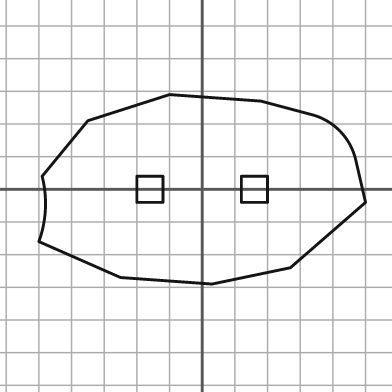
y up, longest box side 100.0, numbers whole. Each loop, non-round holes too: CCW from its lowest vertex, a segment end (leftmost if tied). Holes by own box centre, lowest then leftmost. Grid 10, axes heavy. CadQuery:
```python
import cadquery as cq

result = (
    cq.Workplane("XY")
    .moveTo(3.0, -29.0)
    .lineTo(27.0, -24.0)
    .lineTo(50.0, -4.0)
    .lineTo(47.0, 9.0)
    .threePointArc((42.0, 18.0), (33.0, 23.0))
    .lineTo(18.0, 27.0)
    .lineTo(-10.0, 29.0)
    .lineTo(-35.0, 21.0)
    .lineTo(-49.0, 4.0)
    .threePointArc((-48.0, -6.0), (-50.0, -16.0))
    .lineTo(-25.0, -27.0)
    .close()
    .moveTo(-20.0, -4.0)
    .lineTo(-12.0, -4.0)
    .lineTo(-12.0, 4.0)
    .lineTo(-20.0, 4.0)
    .close()
    .moveTo(12.0, -4.0)
    .lineTo(20.0, -4.0)
    .lineTo(20.0, 4.0)
    .lineTo(12.0, 4.0)
    .close()
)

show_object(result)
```